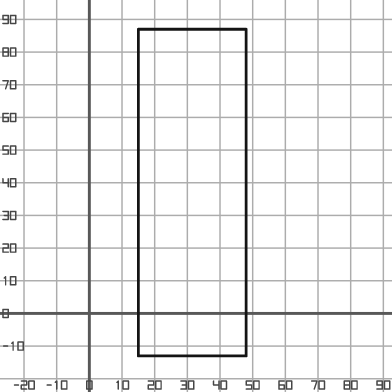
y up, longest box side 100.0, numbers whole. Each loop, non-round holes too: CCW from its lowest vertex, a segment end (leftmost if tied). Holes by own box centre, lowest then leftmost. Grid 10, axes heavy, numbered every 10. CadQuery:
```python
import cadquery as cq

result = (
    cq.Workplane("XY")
    .moveTo(15.0, -13.0)
    .lineTo(48.0, -13.0)
    .lineTo(48.0, 87.0)
    .lineTo(15.0, 87.0)
    .close()
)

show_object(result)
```